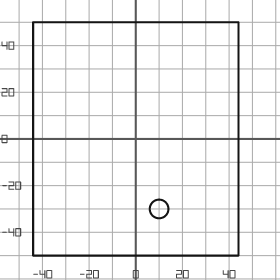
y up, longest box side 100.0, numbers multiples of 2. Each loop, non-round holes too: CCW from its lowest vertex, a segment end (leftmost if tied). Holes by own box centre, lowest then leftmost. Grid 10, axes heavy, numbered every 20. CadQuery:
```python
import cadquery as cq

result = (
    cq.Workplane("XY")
    .moveTo(-44.0, -50.0)
    .lineTo(44.0, -50.0)
    .lineTo(44.0, 50.0)
    .lineTo(-44.0, 50.0)
    .close()
    .moveTo(10.0, -30.0)
    .circle(4.0)
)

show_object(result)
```